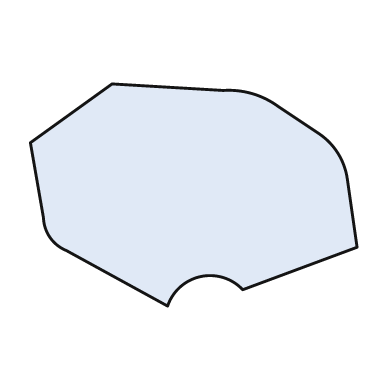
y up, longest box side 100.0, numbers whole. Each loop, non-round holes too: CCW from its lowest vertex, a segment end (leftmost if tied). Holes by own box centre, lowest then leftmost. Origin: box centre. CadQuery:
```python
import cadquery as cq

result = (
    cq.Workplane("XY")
    .moveTo(-8.0, -34.0)
    .threePointArc((2.0, -25.0), (15.0, -29.0))
    .lineTo(50.0, -16.0)
    .lineTo(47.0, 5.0)
    .threePointArc((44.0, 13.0), (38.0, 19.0))
    .lineTo(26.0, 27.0)
    .threePointArc((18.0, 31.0), (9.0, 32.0))
    .lineTo(-25.0, 34.0)
    .lineTo(-50.0, 16.0)
    .lineTo(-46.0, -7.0)
    .threePointArc((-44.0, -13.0), (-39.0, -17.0))
    .close()
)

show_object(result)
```